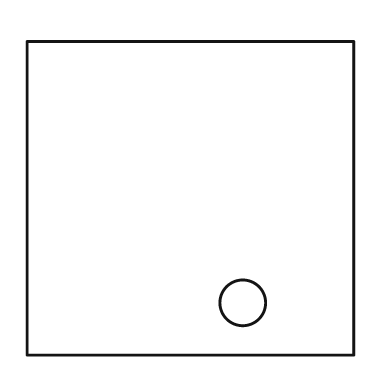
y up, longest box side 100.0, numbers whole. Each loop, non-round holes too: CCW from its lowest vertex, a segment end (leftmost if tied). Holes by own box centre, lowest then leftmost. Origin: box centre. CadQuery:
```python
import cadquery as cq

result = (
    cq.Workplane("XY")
    .moveTo(-50.0, -48.0)
    .lineTo(50.0, -48.0)
    .lineTo(50.0, 48.0)
    .lineTo(-50.0, 48.0)
    .close()
    .moveTo(16.0, -32.0)
    .circle(7.0)
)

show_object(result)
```